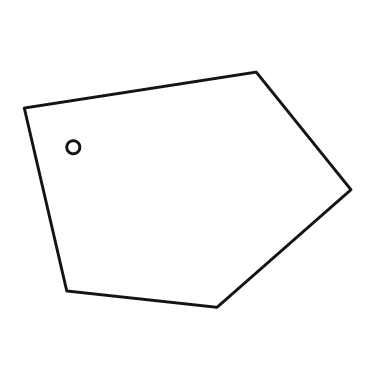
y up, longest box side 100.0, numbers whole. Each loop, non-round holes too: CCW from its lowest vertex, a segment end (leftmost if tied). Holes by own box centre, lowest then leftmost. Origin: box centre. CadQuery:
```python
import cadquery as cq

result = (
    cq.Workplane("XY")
    .moveTo(9.0, -36.0)
    .lineTo(50.0, 0.0)
    .lineTo(21.0, 36.0)
    .lineTo(-50.0, 25.0)
    .lineTo(-37.0, -31.0)
    .close()
    .moveTo(-35.0, 13.0)
    .circle(2.0)
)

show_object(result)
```